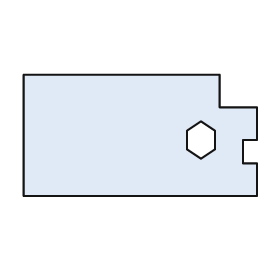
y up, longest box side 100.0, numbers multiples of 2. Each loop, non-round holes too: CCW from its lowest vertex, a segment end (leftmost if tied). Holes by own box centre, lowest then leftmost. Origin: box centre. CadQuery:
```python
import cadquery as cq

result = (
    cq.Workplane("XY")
    .moveTo(-50.0, -26.0)
    .lineTo(50.0, -26.0)
    .lineTo(50.0, -12.0)
    .lineTo(44.0, -12.0)
    .lineTo(44.0, -2.0)
    .lineTo(50.0, -2.0)
    .lineTo(50.0, 12.0)
    .lineTo(34.0, 12.0)
    .lineTo(34.0, 26.0)
    .lineTo(-50.0, 26.0)
    .close()
    .moveTo(26.0, -10.0)
    .lineTo(32.0, -6.0)
    .lineTo(32.0, 2.0)
    .lineTo(26.0, 6.0)
    .lineTo(20.0, 2.0)
    .lineTo(20.0, -6.0)
    .close()
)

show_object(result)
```